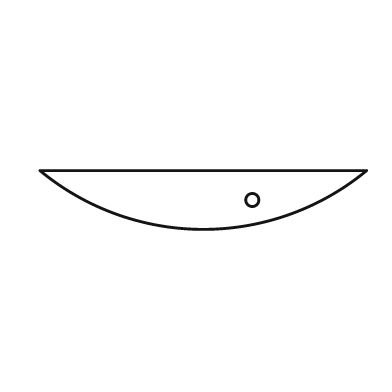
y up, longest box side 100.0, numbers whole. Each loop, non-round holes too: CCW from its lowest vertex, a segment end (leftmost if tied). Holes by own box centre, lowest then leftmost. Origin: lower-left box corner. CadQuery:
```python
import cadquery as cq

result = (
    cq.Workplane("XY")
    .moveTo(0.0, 18.0)
    .threePointArc((50.0, 0.0), (100.0, 18.0))
    .close()
    .moveTo(65.0, 9.0)
    .circle(2.0)
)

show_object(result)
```